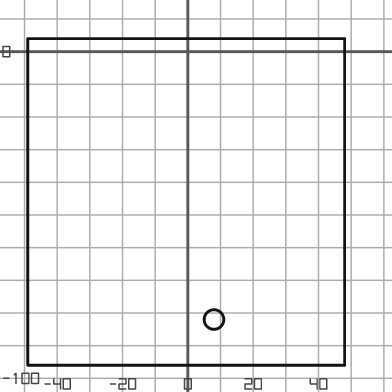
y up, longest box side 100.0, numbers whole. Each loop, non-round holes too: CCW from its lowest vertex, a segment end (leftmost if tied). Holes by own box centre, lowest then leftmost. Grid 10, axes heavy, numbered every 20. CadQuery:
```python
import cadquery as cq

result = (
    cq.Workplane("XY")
    .moveTo(-49.0, -96.0)
    .lineTo(48.0, -96.0)
    .lineTo(48.0, 4.0)
    .lineTo(-49.0, 4.0)
    .close()
    .moveTo(8.0, -82.0)
    .circle(3.0)
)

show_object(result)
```